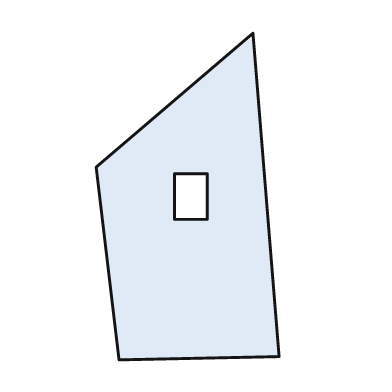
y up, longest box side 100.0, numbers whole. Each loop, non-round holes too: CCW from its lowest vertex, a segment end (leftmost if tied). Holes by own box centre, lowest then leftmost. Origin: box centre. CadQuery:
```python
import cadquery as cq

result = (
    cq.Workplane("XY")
    .moveTo(-21.0, -50.0)
    .lineTo(28.0, -49.0)
    .lineTo(20.0, 50.0)
    .lineTo(-28.0, 9.0)
    .close()
    .moveTo(-4.0, -7.0)
    .lineTo(6.0, -7.0)
    .lineTo(6.0, 7.0)
    .lineTo(-4.0, 7.0)
    .close()
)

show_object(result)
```